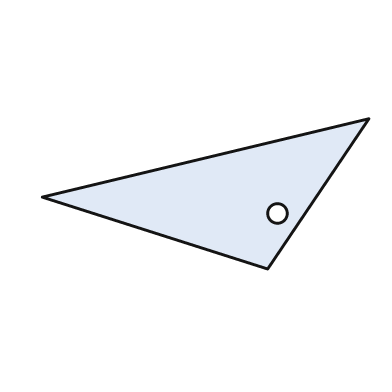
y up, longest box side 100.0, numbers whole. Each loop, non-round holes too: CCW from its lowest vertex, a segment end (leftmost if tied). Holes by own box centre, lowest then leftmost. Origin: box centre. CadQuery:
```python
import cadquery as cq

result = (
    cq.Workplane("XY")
    .moveTo(19.0, -23.0)
    .lineTo(50.0, 23.0)
    .lineTo(-50.0, -1.0)
    .close()
    .moveTo(22.0, -6.0)
    .circle(3.0)
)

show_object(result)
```